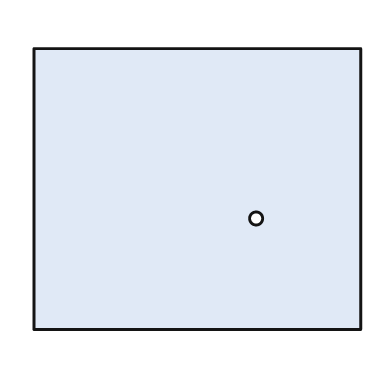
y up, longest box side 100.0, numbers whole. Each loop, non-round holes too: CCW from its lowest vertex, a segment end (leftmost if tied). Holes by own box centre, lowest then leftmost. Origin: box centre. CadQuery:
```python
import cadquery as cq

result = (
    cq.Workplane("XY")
    .moveTo(-50.0, -43.0)
    .lineTo(50.0, -43.0)
    .lineTo(50.0, 43.0)
    .lineTo(-50.0, 43.0)
    .close()
    .moveTo(18.0, -9.0)
    .circle(2.0)
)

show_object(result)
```